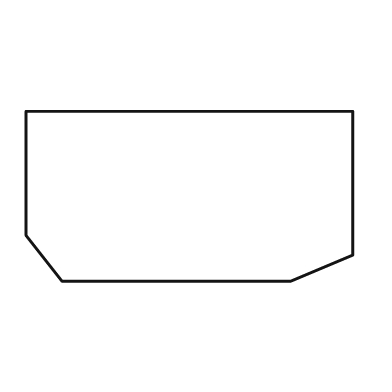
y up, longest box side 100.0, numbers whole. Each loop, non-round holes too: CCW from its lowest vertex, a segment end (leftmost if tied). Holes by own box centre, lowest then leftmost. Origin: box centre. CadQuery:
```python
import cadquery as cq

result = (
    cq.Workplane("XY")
    .moveTo(-39.0, -26.0)
    .lineTo(31.0, -26.0)
    .lineTo(50.0, -18.0)
    .lineTo(50.0, 26.0)
    .lineTo(-50.0, 26.0)
    .lineTo(-50.0, -12.0)
    .close()
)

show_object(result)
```